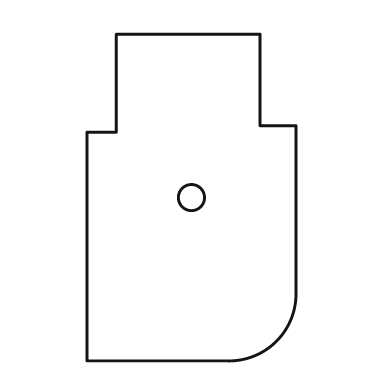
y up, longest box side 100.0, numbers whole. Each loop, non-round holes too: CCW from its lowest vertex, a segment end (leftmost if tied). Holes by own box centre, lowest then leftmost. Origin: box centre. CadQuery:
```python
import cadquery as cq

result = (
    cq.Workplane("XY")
    .moveTo(-32.0, -50.0)
    .lineTo(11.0, -50.0)
    .threePointArc((26.0, -44.0), (32.0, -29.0))
    .lineTo(32.0, 22.0)
    .lineTo(21.0, 22.0)
    .lineTo(21.0, 50.0)
    .lineTo(-23.0, 50.0)
    .lineTo(-23.0, 20.0)
    .lineTo(-32.0, 20.0)
    .close()
    .moveTo(0.0, 0.0)
    .circle(4.0)
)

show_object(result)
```